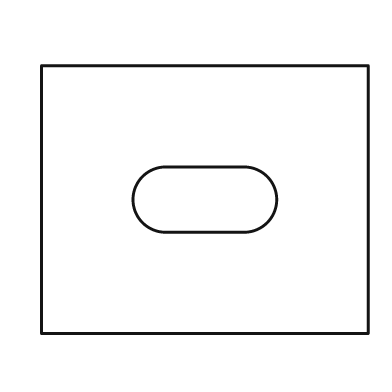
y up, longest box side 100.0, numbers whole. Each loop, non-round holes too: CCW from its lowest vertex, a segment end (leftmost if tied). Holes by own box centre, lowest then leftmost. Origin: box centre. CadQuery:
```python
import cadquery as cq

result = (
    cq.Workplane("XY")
    .moveTo(-50.0, -41.0)
    .lineTo(50.0, -41.0)
    .lineTo(50.0, 41.0)
    .lineTo(-50.0, 41.0)
    .close()
    .moveTo(-12.0, -10.0)
    .lineTo(12.0, -10.0)
    .threePointArc((22.0, 0.0), (12.0, 10.0))
    .lineTo(-12.0, 10.0)
    .threePointArc((-22.0, 0.0), (-12.0, -10.0))
    .close()
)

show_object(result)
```